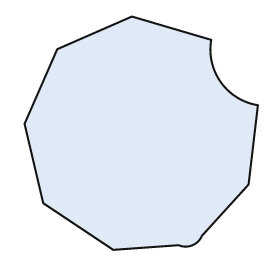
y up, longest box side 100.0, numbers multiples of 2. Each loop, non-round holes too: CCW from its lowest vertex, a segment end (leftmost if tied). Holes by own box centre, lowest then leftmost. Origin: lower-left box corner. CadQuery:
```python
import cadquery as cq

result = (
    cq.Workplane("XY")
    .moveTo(38.0, 0.0)
    .lineTo(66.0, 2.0)
    .threePointArc((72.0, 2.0), (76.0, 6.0))
    .lineTo(96.0, 28.0)
    .lineTo(100.0, 62.0)
    .threePointArc((84.0, 72.0), (80.0, 90.0))
    .lineTo(46.0, 100.0)
    .lineTo(14.0, 86.0)
    .lineTo(0.0, 54.0)
    .lineTo(8.0, 20.0)
    .close()
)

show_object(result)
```